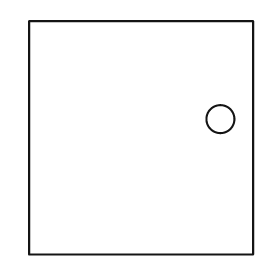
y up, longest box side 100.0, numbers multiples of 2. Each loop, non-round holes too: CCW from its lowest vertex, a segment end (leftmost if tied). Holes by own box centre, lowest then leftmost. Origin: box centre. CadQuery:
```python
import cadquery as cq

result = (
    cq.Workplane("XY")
    .moveTo(-48.0, -50.0)
    .lineTo(48.0, -50.0)
    .lineTo(48.0, 50.0)
    .lineTo(-48.0, 50.0)
    .close()
    .moveTo(34.0, 8.0)
    .circle(6.0)
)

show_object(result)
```